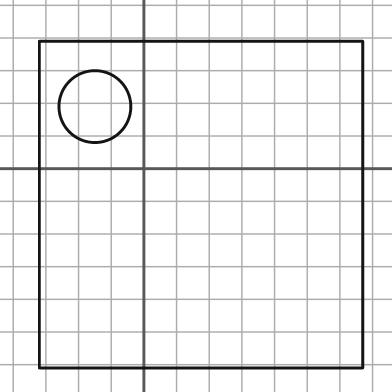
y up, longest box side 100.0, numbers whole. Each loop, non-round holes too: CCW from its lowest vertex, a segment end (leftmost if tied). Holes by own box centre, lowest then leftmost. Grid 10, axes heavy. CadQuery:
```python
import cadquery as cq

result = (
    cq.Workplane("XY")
    .moveTo(-32.0, -61.0)
    .lineTo(67.0, -61.0)
    .lineTo(67.0, 39.0)
    .lineTo(-32.0, 39.0)
    .close()
    .moveTo(-15.0, 19.0)
    .circle(11.0)
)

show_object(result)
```